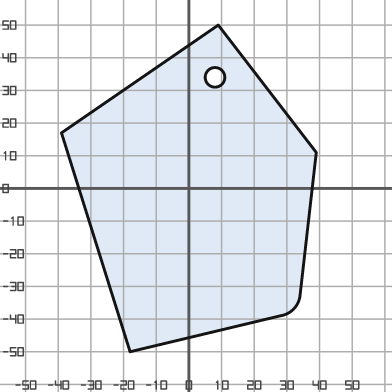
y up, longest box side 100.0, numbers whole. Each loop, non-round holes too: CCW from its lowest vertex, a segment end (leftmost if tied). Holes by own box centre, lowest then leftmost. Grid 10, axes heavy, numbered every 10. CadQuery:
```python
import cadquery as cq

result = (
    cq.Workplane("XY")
    .moveTo(-18.0, -50.0)
    .lineTo(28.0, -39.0)
    .threePointArc((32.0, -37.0), (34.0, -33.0))
    .lineTo(39.0, 11.0)
    .lineTo(9.0, 50.0)
    .lineTo(-39.0, 17.0)
    .close()
    .moveTo(8.0, 34.0)
    .circle(3.0)
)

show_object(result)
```